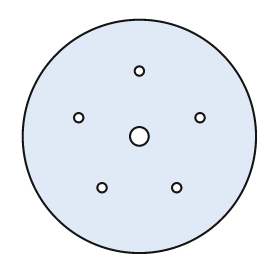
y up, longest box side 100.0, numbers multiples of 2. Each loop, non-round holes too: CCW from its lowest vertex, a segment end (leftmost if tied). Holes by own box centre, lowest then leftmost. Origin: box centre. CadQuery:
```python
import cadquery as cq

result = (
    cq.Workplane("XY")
    .moveTo(0.0, 0.0)
    .circle(50.0)
    .moveTo(-16.0, -22.0)
    .circle(2.0)
    .moveTo(16.0, -22.0)
    .circle(2.0)
    .moveTo(0.0, 0.0)
    .circle(4.0)
    .moveTo(-26.0, 8.0)
    .circle(2.0)
    .moveTo(26.0, 8.0)
    .circle(2.0)
    .moveTo(0.0, 28.0)
    .circle(2.0)
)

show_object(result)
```